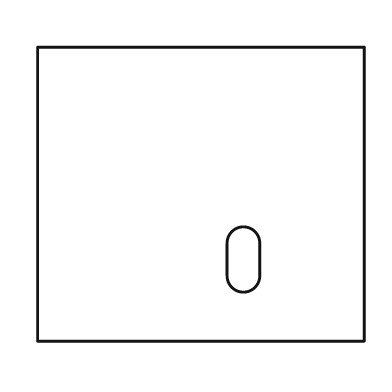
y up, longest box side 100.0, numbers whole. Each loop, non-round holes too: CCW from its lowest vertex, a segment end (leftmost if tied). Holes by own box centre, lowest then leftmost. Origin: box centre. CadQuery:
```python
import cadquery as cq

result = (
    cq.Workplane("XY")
    .moveTo(-50.0, -45.0)
    .lineTo(50.0, -45.0)
    .lineTo(50.0, 45.0)
    .lineTo(-50.0, 45.0)
    .close()
    .moveTo(8.0, -25.0)
    .threePointArc((13.0, -30.0), (18.0, -25.0))
    .lineTo(18.0, -15.0)
    .threePointArc((13.0, -10.0), (8.0, -15.0))
    .close()
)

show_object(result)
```